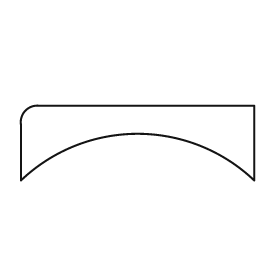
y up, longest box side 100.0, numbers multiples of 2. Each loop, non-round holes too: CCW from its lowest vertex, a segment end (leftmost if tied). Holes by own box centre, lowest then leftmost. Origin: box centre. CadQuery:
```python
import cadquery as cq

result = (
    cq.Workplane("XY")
    .moveTo(-50.0, -16.0)
    .threePointArc((0.0, 4.0), (50.0, -16.0))
    .lineTo(50.0, 16.0)
    .lineTo(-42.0, 16.0)
    .threePointArc((-48.0, 14.0), (-50.0, 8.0))
    .close()
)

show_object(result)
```